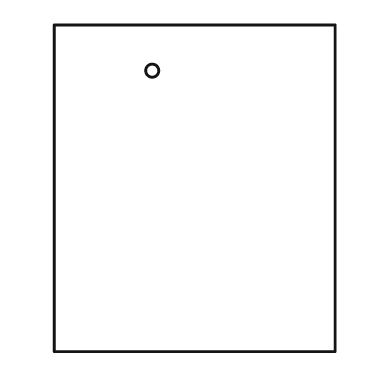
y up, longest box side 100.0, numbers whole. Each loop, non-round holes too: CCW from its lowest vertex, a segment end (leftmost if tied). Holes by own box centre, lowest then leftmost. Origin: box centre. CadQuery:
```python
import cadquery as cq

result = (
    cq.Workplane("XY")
    .moveTo(-43.0, -50.0)
    .lineTo(43.0, -50.0)
    .lineTo(43.0, 50.0)
    .lineTo(-43.0, 50.0)
    .close()
    .moveTo(-13.0, 36.0)
    .circle(2.0)
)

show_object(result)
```